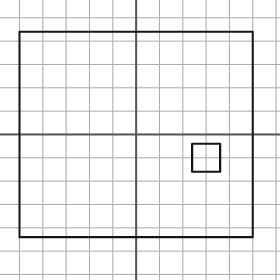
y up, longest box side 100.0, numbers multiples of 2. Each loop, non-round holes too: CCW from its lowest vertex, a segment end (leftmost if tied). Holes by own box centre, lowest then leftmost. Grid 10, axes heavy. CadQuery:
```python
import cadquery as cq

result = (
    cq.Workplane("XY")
    .moveTo(-50.0, -44.0)
    .lineTo(50.0, -44.0)
    .lineTo(50.0, 44.0)
    .lineTo(-50.0, 44.0)
    .close()
    .moveTo(24.0, -16.0)
    .lineTo(36.0, -16.0)
    .lineTo(36.0, -4.0)
    .lineTo(24.0, -4.0)
    .close()
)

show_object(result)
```